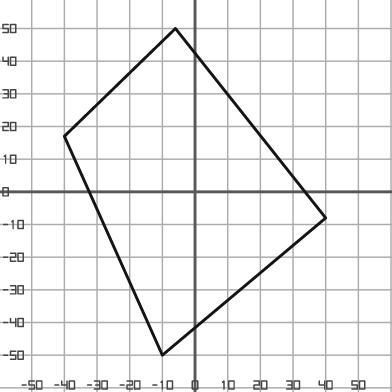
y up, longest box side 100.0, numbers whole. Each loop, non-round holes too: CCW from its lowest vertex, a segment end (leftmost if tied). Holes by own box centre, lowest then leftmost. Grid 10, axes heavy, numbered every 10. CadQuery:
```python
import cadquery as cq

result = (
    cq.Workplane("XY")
    .moveTo(-10.0, -50.0)
    .lineTo(40.0, -8.0)
    .lineTo(-6.0, 50.0)
    .lineTo(-40.0, 17.0)
    .close()
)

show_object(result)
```